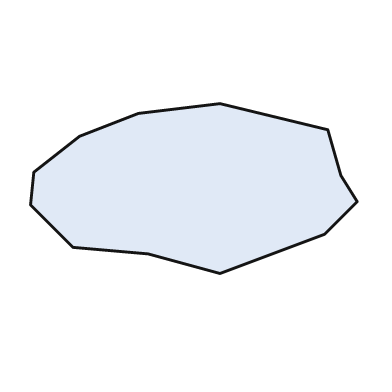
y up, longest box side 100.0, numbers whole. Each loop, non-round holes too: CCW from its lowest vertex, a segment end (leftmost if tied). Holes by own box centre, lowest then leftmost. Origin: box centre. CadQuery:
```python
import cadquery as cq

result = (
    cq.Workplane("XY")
    .moveTo(8.0, -26.0)
    .lineTo(40.0, -14.0)
    .lineTo(50.0, -4.0)
    .lineTo(45.0, 4.0)
    .lineTo(41.0, 18.0)
    .lineTo(8.0, 26.0)
    .lineTo(-17.0, 23.0)
    .lineTo(-35.0, 16.0)
    .lineTo(-49.0, 5.0)
    .lineTo(-50.0, -5.0)
    .lineTo(-37.0, -18.0)
    .lineTo(-14.0, -20.0)
    .close()
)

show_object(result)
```